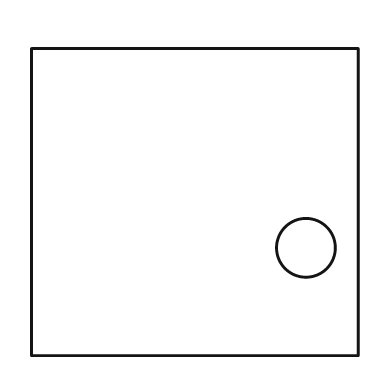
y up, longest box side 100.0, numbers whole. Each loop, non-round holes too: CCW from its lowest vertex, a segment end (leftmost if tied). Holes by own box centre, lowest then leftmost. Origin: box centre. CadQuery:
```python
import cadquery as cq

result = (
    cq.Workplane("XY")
    .moveTo(-50.0, -47.0)
    .lineTo(50.0, -47.0)
    .lineTo(50.0, 47.0)
    .lineTo(-50.0, 47.0)
    .close()
    .moveTo(34.0, -14.0)
    .circle(9.0)
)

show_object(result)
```